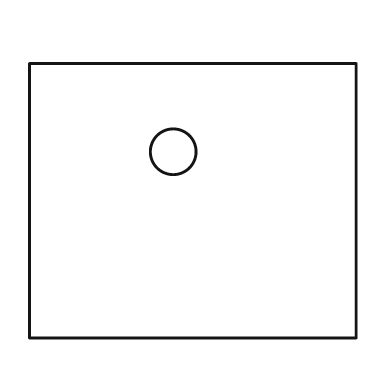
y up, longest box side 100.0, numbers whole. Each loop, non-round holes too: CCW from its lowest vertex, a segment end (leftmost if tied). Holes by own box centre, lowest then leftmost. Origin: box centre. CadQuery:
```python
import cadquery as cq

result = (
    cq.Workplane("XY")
    .moveTo(-50.0, -42.0)
    .lineTo(50.0, -42.0)
    .lineTo(50.0, 42.0)
    .lineTo(-50.0, 42.0)
    .close()
    .moveTo(-6.0, 15.0)
    .circle(7.0)
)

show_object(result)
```